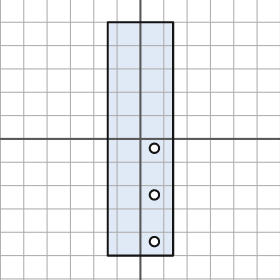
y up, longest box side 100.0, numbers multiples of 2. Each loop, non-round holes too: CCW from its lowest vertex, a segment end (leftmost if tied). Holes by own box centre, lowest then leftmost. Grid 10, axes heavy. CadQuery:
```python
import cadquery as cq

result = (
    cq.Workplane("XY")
    .moveTo(-14.0, -50.0)
    .lineTo(14.0, -50.0)
    .lineTo(14.0, 50.0)
    .lineTo(-14.0, 50.0)
    .close()
    .moveTo(6.0, -44.0)
    .circle(2.0)
    .moveTo(6.0, -24.0)
    .circle(2.0)
    .moveTo(6.0, -4.0)
    .circle(2.0)
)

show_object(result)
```